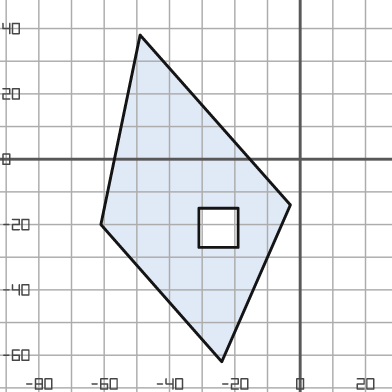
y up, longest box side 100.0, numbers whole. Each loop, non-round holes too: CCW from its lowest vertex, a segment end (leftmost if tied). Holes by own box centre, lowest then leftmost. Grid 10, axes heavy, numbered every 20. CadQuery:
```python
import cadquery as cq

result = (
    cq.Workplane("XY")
    .moveTo(-24.0, -62.0)
    .lineTo(-3.0, -14.0)
    .lineTo(-49.0, 38.0)
    .lineTo(-61.0, -20.0)
    .close()
    .moveTo(-31.0, -27.0)
    .lineTo(-19.0, -27.0)
    .lineTo(-19.0, -15.0)
    .lineTo(-31.0, -15.0)
    .close()
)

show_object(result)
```